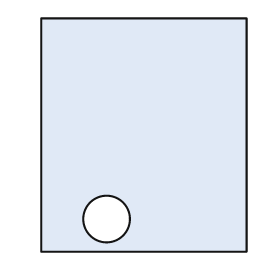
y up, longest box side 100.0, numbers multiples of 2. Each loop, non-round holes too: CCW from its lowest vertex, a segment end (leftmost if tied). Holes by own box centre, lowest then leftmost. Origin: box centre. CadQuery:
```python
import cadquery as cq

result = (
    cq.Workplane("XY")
    .moveTo(-44.0, -50.0)
    .lineTo(44.0, -50.0)
    .lineTo(44.0, 50.0)
    .lineTo(-44.0, 50.0)
    .close()
    .moveTo(-16.0, -36.0)
    .circle(10.0)
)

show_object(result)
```